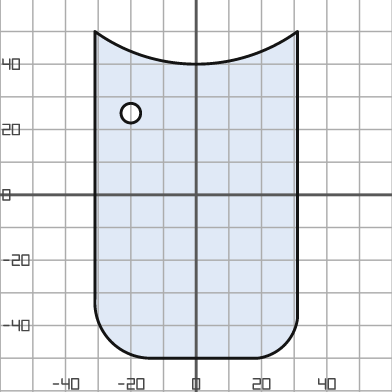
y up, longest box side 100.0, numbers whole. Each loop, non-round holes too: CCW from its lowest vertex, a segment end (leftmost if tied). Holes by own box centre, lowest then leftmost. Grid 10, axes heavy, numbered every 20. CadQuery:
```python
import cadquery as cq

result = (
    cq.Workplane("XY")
    .moveTo(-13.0, -50.0)
    .lineTo(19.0, -50.0)
    .threePointArc((27.0, -46.0), (31.0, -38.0))
    .lineTo(31.0, 50.0)
    .threePointArc((0.0, 40.0), (-31.0, 50.0))
    .lineTo(-31.0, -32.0)
    .threePointArc((-26.0, -45.0), (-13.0, -50.0))
    .close()
    .moveTo(-20.0, 25.0)
    .circle(3.0)
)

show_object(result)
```